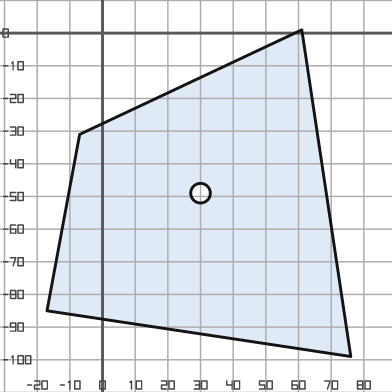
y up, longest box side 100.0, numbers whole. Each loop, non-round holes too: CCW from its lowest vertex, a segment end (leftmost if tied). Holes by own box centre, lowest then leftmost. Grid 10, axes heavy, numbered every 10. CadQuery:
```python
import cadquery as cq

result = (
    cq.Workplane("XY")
    .moveTo(76.0, -99.0)
    .lineTo(61.0, 1.0)
    .lineTo(-7.0, -31.0)
    .lineTo(-17.0, -85.0)
    .close()
    .moveTo(30.0, -49.0)
    .circle(3.0)
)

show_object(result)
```